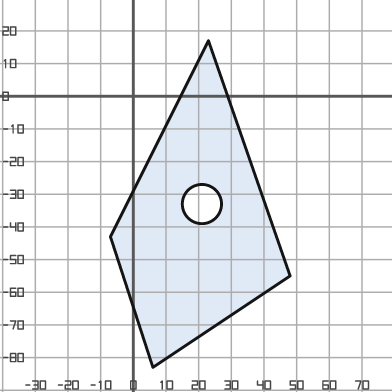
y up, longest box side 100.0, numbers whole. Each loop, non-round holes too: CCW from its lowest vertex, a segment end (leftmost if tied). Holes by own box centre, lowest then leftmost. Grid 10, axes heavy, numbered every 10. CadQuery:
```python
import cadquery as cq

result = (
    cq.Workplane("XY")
    .moveTo(6.0, -83.0)
    .lineTo(48.0, -55.0)
    .lineTo(23.0, 17.0)
    .lineTo(-7.0, -43.0)
    .close()
    .moveTo(21.0, -33.0)
    .circle(6.0)
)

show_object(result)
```